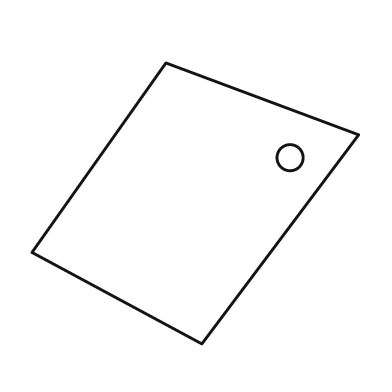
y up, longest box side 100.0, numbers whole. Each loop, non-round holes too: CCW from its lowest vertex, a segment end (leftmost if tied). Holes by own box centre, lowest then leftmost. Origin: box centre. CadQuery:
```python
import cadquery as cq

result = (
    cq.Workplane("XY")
    .moveTo(2.0, -43.0)
    .lineTo(50.0, 21.0)
    .lineTo(-9.0, 43.0)
    .lineTo(-50.0, -15.0)
    .close()
    .moveTo(29.0, 14.0)
    .circle(4.0)
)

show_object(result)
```